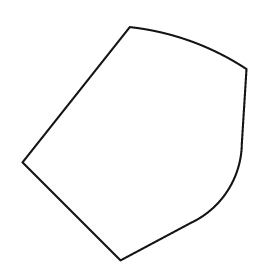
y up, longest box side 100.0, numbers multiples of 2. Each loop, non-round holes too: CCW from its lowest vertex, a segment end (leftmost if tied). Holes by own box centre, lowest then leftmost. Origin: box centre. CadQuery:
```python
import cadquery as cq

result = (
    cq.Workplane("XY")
    .moveTo(-6.0, -50.0)
    .lineTo(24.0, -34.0)
    .threePointArc((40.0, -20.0), (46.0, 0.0))
    .lineTo(48.0, 32.0)
    .threePointArc((24.0, 44.0), (-2.0, 50.0))
    .lineTo(-48.0, -8.0)
    .close()
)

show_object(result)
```